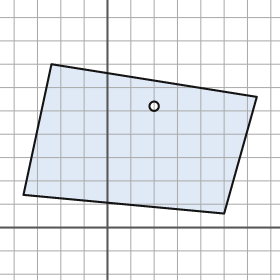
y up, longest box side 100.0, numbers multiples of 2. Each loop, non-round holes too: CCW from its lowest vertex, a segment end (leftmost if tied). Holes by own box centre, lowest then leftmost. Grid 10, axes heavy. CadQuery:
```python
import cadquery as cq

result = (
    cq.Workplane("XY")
    .moveTo(50.0, 6.0)
    .lineTo(64.0, 56.0)
    .lineTo(-24.0, 70.0)
    .lineTo(-36.0, 14.0)
    .close()
    .moveTo(20.0, 52.0)
    .circle(2.0)
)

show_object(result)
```